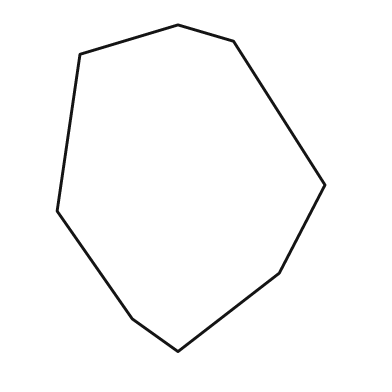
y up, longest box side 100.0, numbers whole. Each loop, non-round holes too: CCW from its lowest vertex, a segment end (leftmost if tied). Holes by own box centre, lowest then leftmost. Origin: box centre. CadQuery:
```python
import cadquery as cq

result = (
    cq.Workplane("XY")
    .moveTo(-4.0, -50.0)
    .lineTo(27.0, -26.0)
    .lineTo(41.0, 1.0)
    .lineTo(13.0, 45.0)
    .lineTo(-4.0, 50.0)
    .lineTo(-34.0, 41.0)
    .lineTo(-41.0, -7.0)
    .lineTo(-18.0, -40.0)
    .close()
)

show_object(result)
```